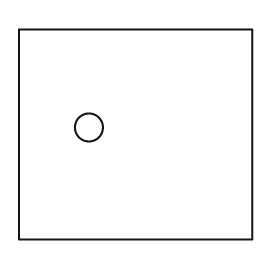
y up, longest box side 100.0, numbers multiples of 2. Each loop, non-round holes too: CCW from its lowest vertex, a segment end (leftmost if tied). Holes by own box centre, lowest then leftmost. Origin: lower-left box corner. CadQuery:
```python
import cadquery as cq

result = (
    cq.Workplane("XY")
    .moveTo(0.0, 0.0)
    .lineTo(100.0, 0.0)
    .lineTo(100.0, 90.0)
    .lineTo(0.0, 90.0)
    .close()
    .moveTo(30.0, 48.0)
    .circle(6.0)
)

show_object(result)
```